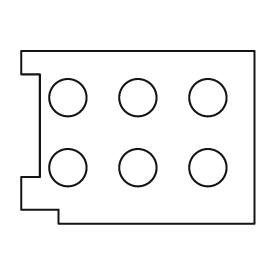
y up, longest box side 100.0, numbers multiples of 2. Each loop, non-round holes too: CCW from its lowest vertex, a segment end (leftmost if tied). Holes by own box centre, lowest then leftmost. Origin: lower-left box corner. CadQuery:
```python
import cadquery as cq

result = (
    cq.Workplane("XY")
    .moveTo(16.0, 0.0)
    .lineTo(100.0, 0.0)
    .lineTo(100.0, 74.0)
    .lineTo(0.0, 74.0)
    .lineTo(0.0, 64.0)
    .lineTo(8.0, 64.0)
    .lineTo(8.0, 20.0)
    .lineTo(0.0, 20.0)
    .lineTo(0.0, 6.0)
    .lineTo(16.0, 6.0)
    .close()
    .moveTo(20.0, 24.0)
    .circle(8.0)
    .moveTo(50.0, 24.0)
    .circle(8.0)
    .moveTo(80.0, 24.0)
    .circle(8.0)
    .moveTo(20.0, 54.0)
    .circle(8.0)
    .moveTo(50.0, 54.0)
    .circle(8.0)
    .moveTo(80.0, 54.0)
    .circle(8.0)
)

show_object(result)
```